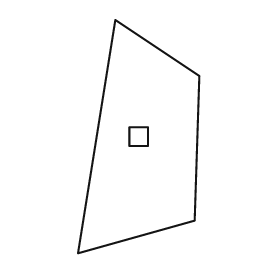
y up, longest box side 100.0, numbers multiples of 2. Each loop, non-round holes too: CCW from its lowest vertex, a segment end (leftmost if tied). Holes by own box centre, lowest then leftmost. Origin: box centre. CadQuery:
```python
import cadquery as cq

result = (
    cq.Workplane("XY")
    .moveTo(-26.0, -50.0)
    .lineTo(24.0, -36.0)
    .lineTo(26.0, 26.0)
    .lineTo(-10.0, 50.0)
    .close()
    .moveTo(-4.0, -4.0)
    .lineTo(4.0, -4.0)
    .lineTo(4.0, 4.0)
    .lineTo(-4.0, 4.0)
    .close()
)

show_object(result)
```